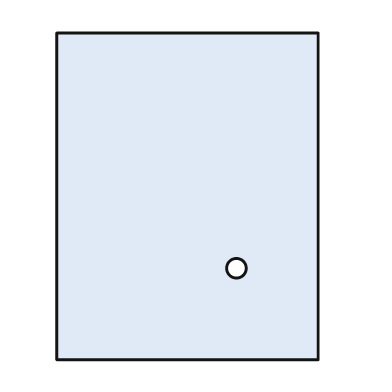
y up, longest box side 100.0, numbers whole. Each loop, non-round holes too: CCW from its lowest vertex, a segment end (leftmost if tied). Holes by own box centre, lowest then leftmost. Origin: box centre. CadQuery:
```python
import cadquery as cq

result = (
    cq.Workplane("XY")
    .moveTo(-40.0, -50.0)
    .lineTo(40.0, -50.0)
    .lineTo(40.0, 50.0)
    .lineTo(-40.0, 50.0)
    .close()
    .moveTo(15.0, -22.0)
    .circle(3.0)
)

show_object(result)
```